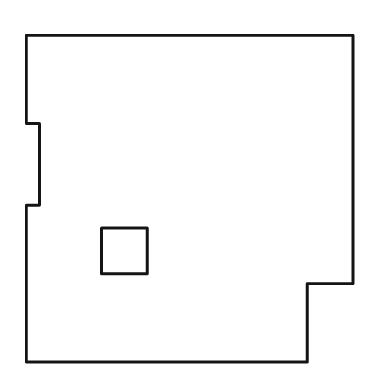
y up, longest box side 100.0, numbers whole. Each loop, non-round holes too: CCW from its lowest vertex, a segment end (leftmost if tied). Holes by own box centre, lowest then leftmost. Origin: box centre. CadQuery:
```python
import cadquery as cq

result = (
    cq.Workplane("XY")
    .moveTo(-50.0, -50.0)
    .lineTo(36.0, -50.0)
    .lineTo(36.0, -26.0)
    .lineTo(50.0, -26.0)
    .lineTo(50.0, 50.0)
    .lineTo(-50.0, 50.0)
    .lineTo(-50.0, 23.0)
    .lineTo(-46.0, 23.0)
    .lineTo(-46.0, -2.0)
    .lineTo(-50.0, -2.0)
    .close()
    .moveTo(-27.0, -23.0)
    .lineTo(-13.0, -23.0)
    .lineTo(-13.0, -9.0)
    .lineTo(-27.0, -9.0)
    .close()
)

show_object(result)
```